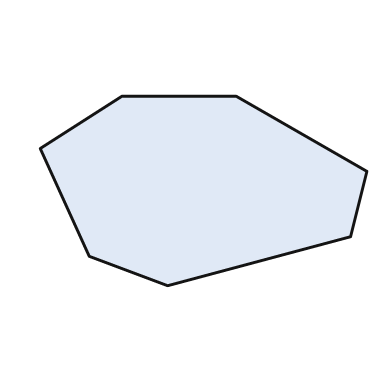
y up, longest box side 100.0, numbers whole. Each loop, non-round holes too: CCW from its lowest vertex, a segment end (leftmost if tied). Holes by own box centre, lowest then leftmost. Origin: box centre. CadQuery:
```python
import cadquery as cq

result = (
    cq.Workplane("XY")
    .moveTo(-11.0, -29.0)
    .lineTo(45.0, -14.0)
    .lineTo(50.0, 6.0)
    .lineTo(10.0, 29.0)
    .lineTo(-25.0, 29.0)
    .lineTo(-50.0, 13.0)
    .lineTo(-35.0, -20.0)
    .close()
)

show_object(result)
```